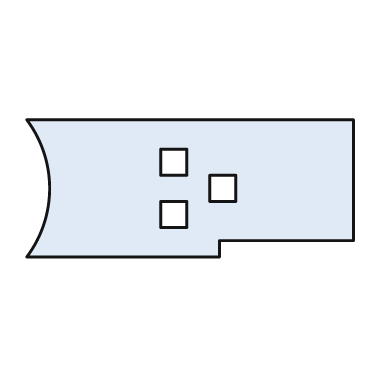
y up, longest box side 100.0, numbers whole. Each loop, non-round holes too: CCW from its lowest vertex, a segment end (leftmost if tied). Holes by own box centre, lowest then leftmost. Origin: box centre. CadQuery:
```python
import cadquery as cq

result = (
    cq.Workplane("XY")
    .moveTo(-50.0, -21.0)
    .lineTo(9.0, -21.0)
    .lineTo(9.0, -16.0)
    .lineTo(50.0, -16.0)
    .lineTo(50.0, 21.0)
    .lineTo(-50.0, 21.0)
    .threePointArc((-43.0, 0.0), (-50.0, -21.0))
    .close()
    .moveTo(-9.0, -12.0)
    .lineTo(-1.0, -12.0)
    .lineTo(-1.0, -4.0)
    .lineTo(-9.0, -4.0)
    .close()
    .moveTo(6.0, -4.0)
    .lineTo(14.0, -4.0)
    .lineTo(14.0, 4.0)
    .lineTo(6.0, 4.0)
    .close()
    .moveTo(-9.0, 4.0)
    .lineTo(-1.0, 4.0)
    .lineTo(-1.0, 12.0)
    .lineTo(-9.0, 12.0)
    .close()
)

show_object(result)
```